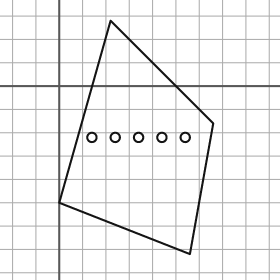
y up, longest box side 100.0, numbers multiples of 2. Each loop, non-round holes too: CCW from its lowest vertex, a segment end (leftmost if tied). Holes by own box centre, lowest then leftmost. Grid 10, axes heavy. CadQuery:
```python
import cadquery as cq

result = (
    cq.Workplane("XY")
    .moveTo(56.0, -72.0)
    .lineTo(66.0, -16.0)
    .lineTo(22.0, 28.0)
    .lineTo(0.0, -50.0)
    .close()
    .moveTo(14.0, -22.0)
    .circle(2.0)
    .moveTo(24.0, -22.0)
    .circle(2.0)
    .moveTo(34.0, -22.0)
    .circle(2.0)
    .moveTo(44.0, -22.0)
    .circle(2.0)
    .moveTo(54.0, -22.0)
    .circle(2.0)
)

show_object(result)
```